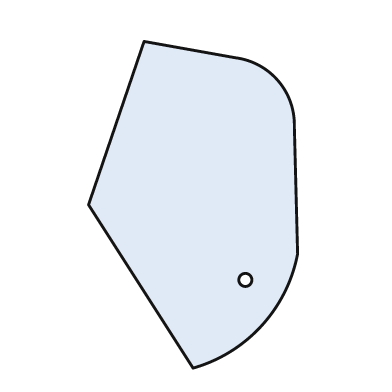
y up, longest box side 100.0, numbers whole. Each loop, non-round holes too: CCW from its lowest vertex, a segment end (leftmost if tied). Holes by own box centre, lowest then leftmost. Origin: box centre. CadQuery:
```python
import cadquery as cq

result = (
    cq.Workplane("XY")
    .moveTo(0.0, -50.0)
    .threePointArc((21.0, -37.0), (32.0, -15.0))
    .lineTo(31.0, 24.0)
    .threePointArc((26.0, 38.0), (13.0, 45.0))
    .lineTo(-15.0, 50.0)
    .lineTo(-32.0, 0.0)
    .close()
    .moveTo(16.0, -23.0)
    .circle(2.0)
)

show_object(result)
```